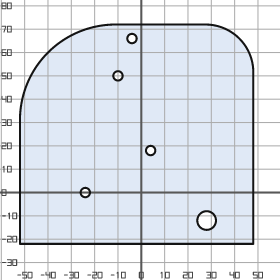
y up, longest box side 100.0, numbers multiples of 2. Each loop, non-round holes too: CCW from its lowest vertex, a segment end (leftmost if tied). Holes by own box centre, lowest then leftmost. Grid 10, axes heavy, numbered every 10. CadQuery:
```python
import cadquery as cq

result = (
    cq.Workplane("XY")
    .moveTo(-52.0, -22.0)
    .lineTo(48.0, -22.0)
    .lineTo(48.0, 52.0)
    .threePointArc((42.0, 66.0), (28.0, 72.0))
    .lineTo(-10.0, 72.0)
    .threePointArc((-40.0, 60.0), (-52.0, 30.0))
    .close()
    .moveTo(28.0, -12.0)
    .circle(4.0)
    .moveTo(-24.0, 0.0)
    .circle(2.0)
    .moveTo(4.0, 18.0)
    .circle(2.0)
    .moveTo(-10.0, 50.0)
    .circle(2.0)
    .moveTo(-4.0, 66.0)
    .circle(2.0)
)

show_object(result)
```